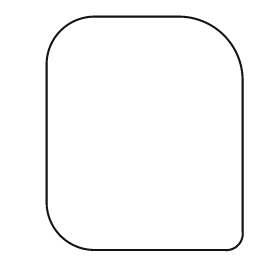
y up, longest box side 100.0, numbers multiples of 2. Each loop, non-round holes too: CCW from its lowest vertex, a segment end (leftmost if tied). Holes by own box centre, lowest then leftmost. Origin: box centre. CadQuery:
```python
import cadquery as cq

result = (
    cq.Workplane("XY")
    .moveTo(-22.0, -50.0)
    .lineTo(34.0, -50.0)
    .threePointArc((40.0, -48.0), (42.0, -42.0))
    .lineTo(42.0, 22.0)
    .threePointArc((34.0, 42.0), (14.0, 50.0))
    .lineTo(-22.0, 50.0)
    .threePointArc((-36.0, 44.0), (-42.0, 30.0))
    .lineTo(-42.0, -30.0)
    .threePointArc((-36.0, -44.0), (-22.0, -50.0))
    .close()
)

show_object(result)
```